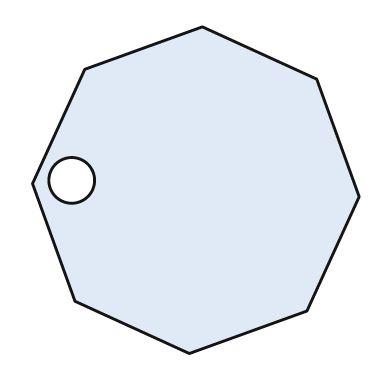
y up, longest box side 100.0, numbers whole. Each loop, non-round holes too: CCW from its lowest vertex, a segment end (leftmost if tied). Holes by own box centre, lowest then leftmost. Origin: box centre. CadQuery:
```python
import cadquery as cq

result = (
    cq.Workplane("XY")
    .moveTo(-2.0, -50.0)
    .lineTo(34.0, -37.0)
    .lineTo(50.0, -2.0)
    .lineTo(37.0, 34.0)
    .lineTo(2.0, 50.0)
    .lineTo(-34.0, 37.0)
    .lineTo(-50.0, 2.0)
    .lineTo(-37.0, -34.0)
    .close()
    .moveTo(-38.0, 3.0)
    .circle(7.0)
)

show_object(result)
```